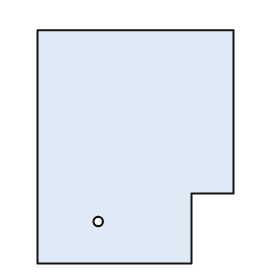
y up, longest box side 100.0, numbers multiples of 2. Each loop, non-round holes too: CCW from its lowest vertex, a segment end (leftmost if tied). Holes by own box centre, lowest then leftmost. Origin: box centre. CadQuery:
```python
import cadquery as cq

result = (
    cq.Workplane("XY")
    .moveTo(-42.0, -50.0)
    .lineTo(24.0, -50.0)
    .lineTo(24.0, -20.0)
    .lineTo(42.0, -20.0)
    .lineTo(42.0, 50.0)
    .lineTo(-42.0, 50.0)
    .close()
    .moveTo(-16.0, -32.0)
    .circle(2.0)
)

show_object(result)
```